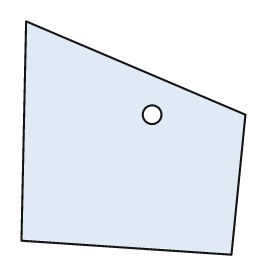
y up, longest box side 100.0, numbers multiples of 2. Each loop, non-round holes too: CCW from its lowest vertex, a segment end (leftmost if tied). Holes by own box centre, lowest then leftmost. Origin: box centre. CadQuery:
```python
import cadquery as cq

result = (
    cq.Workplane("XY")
    .moveTo(42.0, -50.0)
    .lineTo(48.0, 10.0)
    .lineTo(-46.0, 50.0)
    .lineTo(-48.0, -44.0)
    .close()
    .moveTo(8.0, 10.0)
    .circle(4.0)
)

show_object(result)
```